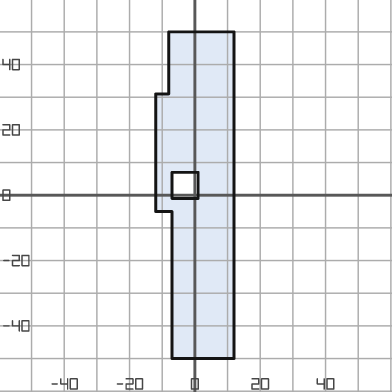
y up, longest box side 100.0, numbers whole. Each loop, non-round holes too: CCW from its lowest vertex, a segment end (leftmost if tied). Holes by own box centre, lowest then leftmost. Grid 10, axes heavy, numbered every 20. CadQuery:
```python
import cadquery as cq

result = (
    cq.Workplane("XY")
    .moveTo(-7.0, -50.0)
    .lineTo(12.0, -50.0)
    .lineTo(12.0, 50.0)
    .lineTo(-8.0, 50.0)
    .lineTo(-8.0, 31.0)
    .lineTo(-12.0, 31.0)
    .lineTo(-12.0, -5.0)
    .lineTo(-7.0, -5.0)
    .close()
    .moveTo(-7.0, -1.0)
    .lineTo(1.0, -1.0)
    .lineTo(1.0, 7.0)
    .lineTo(-7.0, 7.0)
    .close()
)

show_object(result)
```